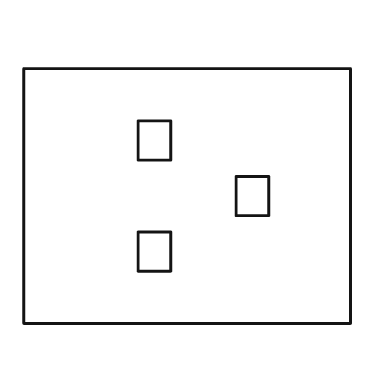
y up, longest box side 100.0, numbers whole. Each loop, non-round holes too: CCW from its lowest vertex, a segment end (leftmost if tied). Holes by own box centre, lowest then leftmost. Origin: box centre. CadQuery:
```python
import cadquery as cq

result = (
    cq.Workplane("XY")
    .moveTo(-50.0, -39.0)
    .lineTo(50.0, -39.0)
    .lineTo(50.0, 39.0)
    .lineTo(-50.0, 39.0)
    .close()
    .moveTo(-15.0, -23.0)
    .lineTo(-5.0, -23.0)
    .lineTo(-5.0, -11.0)
    .lineTo(-15.0, -11.0)
    .close()
    .moveTo(15.0, -6.0)
    .lineTo(25.0, -6.0)
    .lineTo(25.0, 6.0)
    .lineTo(15.0, 6.0)
    .close()
    .moveTo(-15.0, 11.0)
    .lineTo(-5.0, 11.0)
    .lineTo(-5.0, 23.0)
    .lineTo(-15.0, 23.0)
    .close()
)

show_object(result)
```